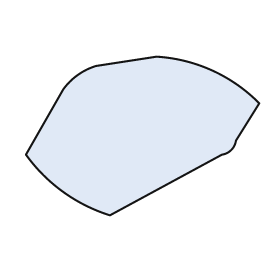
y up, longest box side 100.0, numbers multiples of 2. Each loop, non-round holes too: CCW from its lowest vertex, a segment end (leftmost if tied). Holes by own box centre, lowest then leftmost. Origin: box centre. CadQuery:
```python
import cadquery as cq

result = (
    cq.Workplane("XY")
    .moveTo(-14.0, -34.0)
    .lineTo(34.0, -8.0)
    .threePointArc((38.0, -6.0), (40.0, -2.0))
    .lineTo(50.0, 14.0)
    .threePointArc((30.0, 28.0), (6.0, 34.0))
    .lineTo(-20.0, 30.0)
    .threePointArc((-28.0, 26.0), (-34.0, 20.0))
    .lineTo(-50.0, -8.0)
    .threePointArc((-34.0, -24.0), (-14.0, -34.0))
    .close()
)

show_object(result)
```